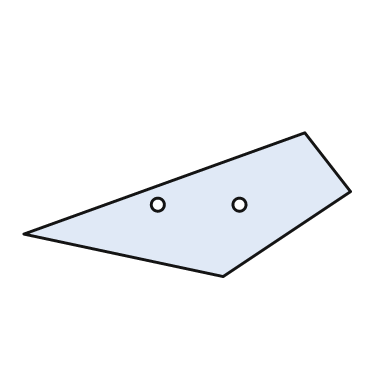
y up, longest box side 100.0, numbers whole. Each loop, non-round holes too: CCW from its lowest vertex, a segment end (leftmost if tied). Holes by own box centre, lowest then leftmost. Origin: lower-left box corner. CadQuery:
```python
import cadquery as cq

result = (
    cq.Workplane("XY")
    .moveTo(61.0, 0.0)
    .lineTo(100.0, 26.0)
    .lineTo(86.0, 44.0)
    .lineTo(0.0, 13.0)
    .close()
    .moveTo(41.0, 22.0)
    .circle(2.0)
    .moveTo(66.0, 22.0)
    .circle(2.0)
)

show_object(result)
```